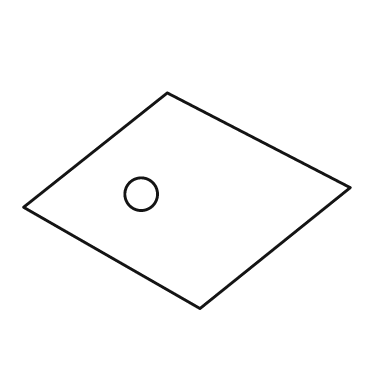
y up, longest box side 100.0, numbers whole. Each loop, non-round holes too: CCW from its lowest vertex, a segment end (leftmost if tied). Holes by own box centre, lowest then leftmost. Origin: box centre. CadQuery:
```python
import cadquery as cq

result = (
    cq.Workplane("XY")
    .moveTo(4.0, -33.0)
    .lineTo(50.0, 4.0)
    .lineTo(-6.0, 33.0)
    .lineTo(-50.0, -2.0)
    .close()
    .moveTo(-14.0, 2.0)
    .circle(5.0)
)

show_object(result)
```